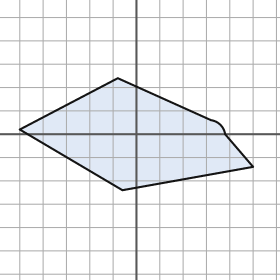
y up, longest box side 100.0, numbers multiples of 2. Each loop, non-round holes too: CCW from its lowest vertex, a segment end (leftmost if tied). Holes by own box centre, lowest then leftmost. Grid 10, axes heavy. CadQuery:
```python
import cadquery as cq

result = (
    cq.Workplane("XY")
    .moveTo(-6.0, -24.0)
    .lineTo(50.0, -14.0)
    .lineTo(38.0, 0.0)
    .threePointArc((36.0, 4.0), (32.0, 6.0))
    .lineTo(-8.0, 24.0)
    .lineTo(-50.0, 2.0)
    .close()
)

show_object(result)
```